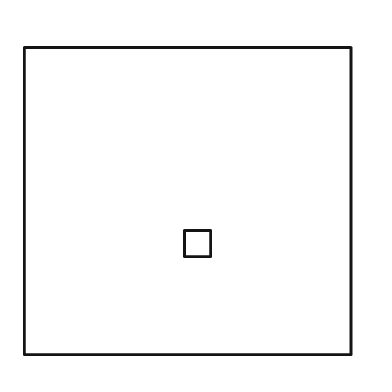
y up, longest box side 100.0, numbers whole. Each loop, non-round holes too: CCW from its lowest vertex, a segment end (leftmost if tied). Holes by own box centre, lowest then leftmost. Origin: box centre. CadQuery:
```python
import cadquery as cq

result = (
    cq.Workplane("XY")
    .moveTo(-50.0, -47.0)
    .lineTo(50.0, -47.0)
    .lineTo(50.0, 47.0)
    .lineTo(-50.0, 47.0)
    .close()
    .moveTo(-1.0, -17.0)
    .lineTo(7.0, -17.0)
    .lineTo(7.0, -9.0)
    .lineTo(-1.0, -9.0)
    .close()
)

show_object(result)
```